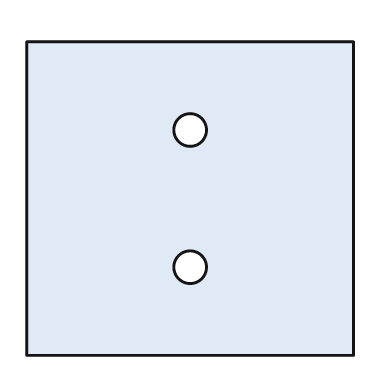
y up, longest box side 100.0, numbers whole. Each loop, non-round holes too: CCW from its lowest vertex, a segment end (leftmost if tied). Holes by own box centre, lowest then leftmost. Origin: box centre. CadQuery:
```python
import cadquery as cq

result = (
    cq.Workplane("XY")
    .moveTo(-50.0, -48.0)
    .lineTo(50.0, -48.0)
    .lineTo(50.0, 48.0)
    .lineTo(-50.0, 48.0)
    .close()
    .moveTo(0.0, -21.0)
    .circle(5.0)
    .moveTo(0.0, 21.0)
    .circle(5.0)
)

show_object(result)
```